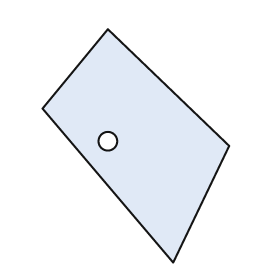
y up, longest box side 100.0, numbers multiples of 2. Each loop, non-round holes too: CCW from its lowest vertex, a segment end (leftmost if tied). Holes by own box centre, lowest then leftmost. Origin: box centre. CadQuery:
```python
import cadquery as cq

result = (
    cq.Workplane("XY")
    .moveTo(16.0, -50.0)
    .lineTo(40.0, 0.0)
    .lineTo(-12.0, 50.0)
    .lineTo(-40.0, 16.0)
    .close()
    .moveTo(-12.0, 2.0)
    .circle(4.0)
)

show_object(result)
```